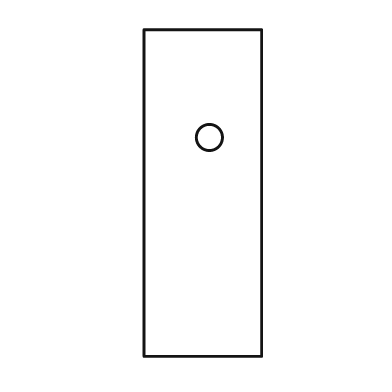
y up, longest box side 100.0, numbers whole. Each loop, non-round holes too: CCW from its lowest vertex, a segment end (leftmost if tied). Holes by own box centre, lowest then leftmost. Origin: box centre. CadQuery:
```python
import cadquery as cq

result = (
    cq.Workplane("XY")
    .moveTo(-18.0, -50.0)
    .lineTo(18.0, -50.0)
    .lineTo(18.0, 50.0)
    .lineTo(-18.0, 50.0)
    .close()
    .moveTo(2.0, 17.0)
    .circle(4.0)
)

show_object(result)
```